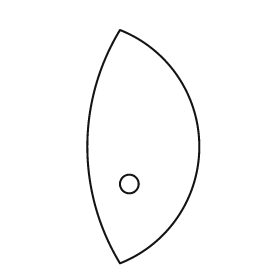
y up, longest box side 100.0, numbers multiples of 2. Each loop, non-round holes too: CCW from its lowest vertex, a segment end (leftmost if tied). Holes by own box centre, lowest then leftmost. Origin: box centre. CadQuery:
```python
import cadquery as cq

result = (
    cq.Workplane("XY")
    .moveTo(-10.0, -50.0)
    .threePointArc((24.0, 0.0), (-10.0, 50.0))
    .threePointArc((-24.0, 0.0), (-10.0, -50.0))
    .close()
    .moveTo(-6.0, -16.0)
    .circle(4.0)
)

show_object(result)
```